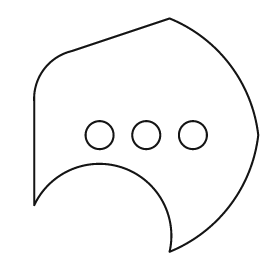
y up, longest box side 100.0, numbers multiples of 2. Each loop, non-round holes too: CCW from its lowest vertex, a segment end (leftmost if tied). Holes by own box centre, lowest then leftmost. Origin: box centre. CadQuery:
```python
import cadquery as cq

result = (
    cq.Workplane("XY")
    .moveTo(10.0, -50.0)
    .threePointArc((36.0, -30.0), (48.0, 0.0))
    .threePointArc((36.0, 30.0), (10.0, 50.0))
    .lineTo(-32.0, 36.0)
    .threePointArc((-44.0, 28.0), (-48.0, 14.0))
    .lineTo(-48.0, -30.0)
    .threePointArc((-10.0, -14.0), (10.0, -50.0))
    .close()
    .moveTo(-20.0, 0.0)
    .circle(6.0)
    .moveTo(0.0, 0.0)
    .circle(6.0)
    .moveTo(20.0, 0.0)
    .circle(6.0)
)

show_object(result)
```